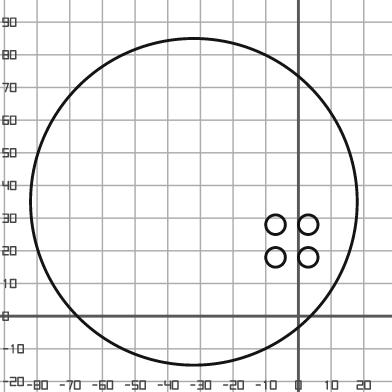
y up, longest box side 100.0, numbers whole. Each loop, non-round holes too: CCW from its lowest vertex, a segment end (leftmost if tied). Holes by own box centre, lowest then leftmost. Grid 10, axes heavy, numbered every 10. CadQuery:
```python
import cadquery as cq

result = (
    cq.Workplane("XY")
    .moveTo(-32.0, 35.0)
    .circle(50.0)
    .moveTo(-7.0, 18.0)
    .circle(3.0)
    .moveTo(3.0, 18.0)
    .circle(3.0)
    .moveTo(-7.0, 28.0)
    .circle(3.0)
    .moveTo(3.0, 28.0)
    .circle(3.0)
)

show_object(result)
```